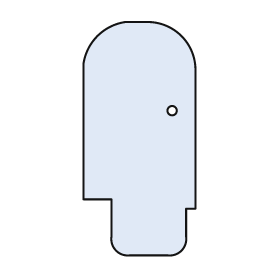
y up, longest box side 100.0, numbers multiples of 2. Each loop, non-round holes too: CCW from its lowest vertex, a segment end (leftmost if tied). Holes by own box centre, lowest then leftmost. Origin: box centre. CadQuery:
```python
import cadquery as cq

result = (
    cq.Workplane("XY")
    .moveTo(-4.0, -50.0)
    .lineTo(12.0, -50.0)
    .threePointArc((18.0, -48.0), (20.0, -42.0))
    .lineTo(20.0, -30.0)
    .lineTo(24.0, -30.0)
    .lineTo(24.0, 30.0)
    .threePointArc((18.0, 44.0), (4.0, 50.0))
    .lineTo(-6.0, 50.0)
    .threePointArc((-18.0, 44.0), (-24.0, 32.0))
    .lineTo(-24.0, -26.0)
    .lineTo(-12.0, -26.0)
    .lineTo(-12.0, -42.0)
    .threePointArc((-10.0, -48.0), (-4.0, -50.0))
    .close()
    .moveTo(14.0, 12.0)
    .circle(2.0)
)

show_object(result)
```